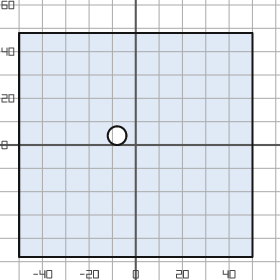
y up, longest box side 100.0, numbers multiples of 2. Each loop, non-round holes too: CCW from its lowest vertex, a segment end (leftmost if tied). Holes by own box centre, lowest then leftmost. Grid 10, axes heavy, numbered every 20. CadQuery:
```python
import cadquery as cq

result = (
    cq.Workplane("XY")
    .moveTo(-50.0, -48.0)
    .lineTo(50.0, -48.0)
    .lineTo(50.0, 48.0)
    .lineTo(-50.0, 48.0)
    .close()
    .moveTo(-8.0, 4.0)
    .circle(4.0)
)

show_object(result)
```